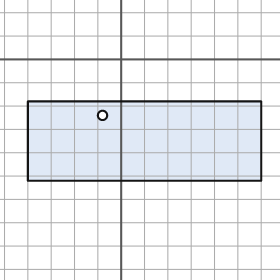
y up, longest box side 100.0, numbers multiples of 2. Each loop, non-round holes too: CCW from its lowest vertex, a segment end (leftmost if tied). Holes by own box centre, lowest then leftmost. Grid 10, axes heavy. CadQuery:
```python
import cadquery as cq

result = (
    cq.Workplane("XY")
    .moveTo(-40.0, -52.0)
    .lineTo(60.0, -52.0)
    .lineTo(60.0, -18.0)
    .lineTo(-40.0, -18.0)
    .close()
    .moveTo(-8.0, -24.0)
    .circle(2.0)
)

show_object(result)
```